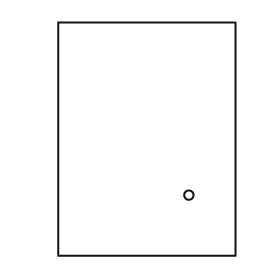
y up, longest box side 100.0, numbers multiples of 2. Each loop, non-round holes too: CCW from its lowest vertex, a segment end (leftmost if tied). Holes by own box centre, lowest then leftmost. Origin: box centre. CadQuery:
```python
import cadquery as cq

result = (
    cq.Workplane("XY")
    .moveTo(-38.0, -50.0)
    .lineTo(38.0, -50.0)
    .lineTo(38.0, 50.0)
    .lineTo(-38.0, 50.0)
    .close()
    .moveTo(18.0, -24.0)
    .circle(2.0)
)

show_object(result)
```